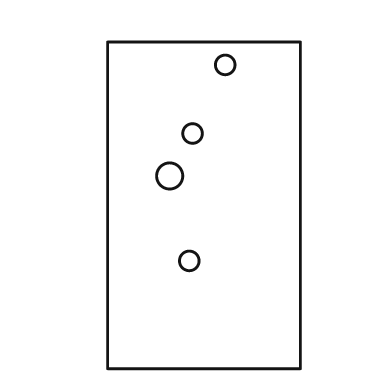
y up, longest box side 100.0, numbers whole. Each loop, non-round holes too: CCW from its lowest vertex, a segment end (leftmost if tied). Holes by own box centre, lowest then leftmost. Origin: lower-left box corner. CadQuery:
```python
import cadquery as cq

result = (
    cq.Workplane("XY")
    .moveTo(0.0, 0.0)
    .lineTo(59.0, 0.0)
    .lineTo(59.0, 100.0)
    .lineTo(0.0, 100.0)
    .close()
    .moveTo(25.0, 33.0)
    .circle(3.0)
    .moveTo(19.0, 59.0)
    .circle(4.0)
    .moveTo(26.0, 72.0)
    .circle(3.0)
    .moveTo(36.0, 93.0)
    .circle(3.0)
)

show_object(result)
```